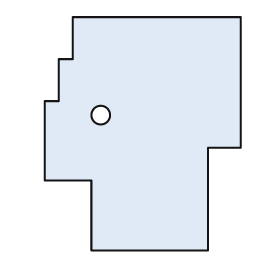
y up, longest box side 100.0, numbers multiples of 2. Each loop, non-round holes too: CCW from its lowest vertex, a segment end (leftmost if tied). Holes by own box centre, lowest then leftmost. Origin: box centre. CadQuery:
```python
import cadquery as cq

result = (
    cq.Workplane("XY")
    .moveTo(-22.0, -50.0)
    .lineTo(28.0, -50.0)
    .lineTo(28.0, -6.0)
    .lineTo(42.0, -6.0)
    .lineTo(42.0, 50.0)
    .lineTo(-30.0, 50.0)
    .lineTo(-30.0, 32.0)
    .lineTo(-36.0, 32.0)
    .lineTo(-36.0, 14.0)
    .lineTo(-42.0, 14.0)
    .lineTo(-42.0, -20.0)
    .lineTo(-22.0, -20.0)
    .close()
    .moveTo(-18.0, 8.0)
    .circle(4.0)
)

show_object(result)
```